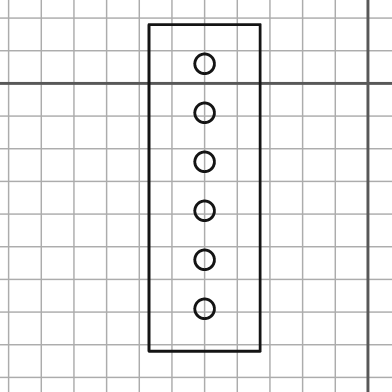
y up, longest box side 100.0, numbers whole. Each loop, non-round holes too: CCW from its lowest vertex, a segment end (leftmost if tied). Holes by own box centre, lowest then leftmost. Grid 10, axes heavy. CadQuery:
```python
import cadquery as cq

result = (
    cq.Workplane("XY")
    .moveTo(-67.0, -82.0)
    .lineTo(-33.0, -82.0)
    .lineTo(-33.0, 18.0)
    .lineTo(-67.0, 18.0)
    .close()
    .moveTo(-50.0, -69.0)
    .circle(3.0)
    .moveTo(-50.0, -54.0)
    .circle(3.0)
    .moveTo(-50.0, -39.0)
    .circle(3.0)
    .moveTo(-50.0, -24.0)
    .circle(3.0)
    .moveTo(-50.0, -9.0)
    .circle(3.0)
    .moveTo(-50.0, 6.0)
    .circle(3.0)
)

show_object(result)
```